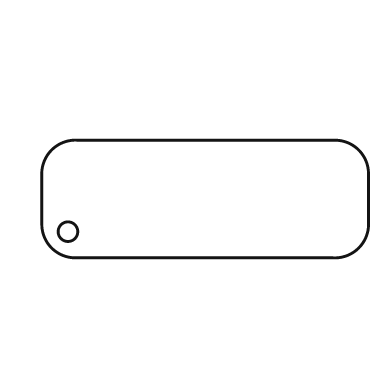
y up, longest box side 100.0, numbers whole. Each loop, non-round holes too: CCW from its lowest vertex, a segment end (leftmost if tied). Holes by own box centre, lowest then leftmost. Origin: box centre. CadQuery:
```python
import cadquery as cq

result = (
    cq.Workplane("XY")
    .moveTo(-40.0, -18.0)
    .lineTo(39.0, -18.0)
    .threePointArc((47.0, -15.0), (50.0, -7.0))
    .lineTo(50.0, 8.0)
    .threePointArc((47.0, 15.0), (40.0, 18.0))
    .lineTo(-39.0, 18.0)
    .threePointArc((-47.0, 15.0), (-50.0, 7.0))
    .lineTo(-50.0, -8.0)
    .threePointArc((-47.0, -15.0), (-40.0, -18.0))
    .close()
    .moveTo(-42.0, -10.0)
    .circle(3.0)
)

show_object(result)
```